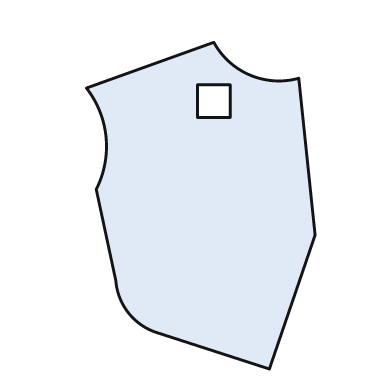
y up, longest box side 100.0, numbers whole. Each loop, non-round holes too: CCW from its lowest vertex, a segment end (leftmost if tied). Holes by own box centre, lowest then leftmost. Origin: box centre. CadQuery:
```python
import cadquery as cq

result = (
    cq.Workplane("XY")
    .moveTo(21.0, -50.0)
    .lineTo(35.0, -9.0)
    .lineTo(30.0, 39.0)
    .threePointArc((15.0, 40.0), (4.0, 50.0))
    .lineTo(-35.0, 36.0)
    .threePointArc((-29.0, 21.0), (-32.0, 5.0))
    .lineTo(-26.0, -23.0)
    .threePointArc((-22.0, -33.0), (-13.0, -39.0))
    .close()
    .moveTo(-1.0, 27.0)
    .lineTo(9.0, 27.0)
    .lineTo(9.0, 37.0)
    .lineTo(-1.0, 37.0)
    .close()
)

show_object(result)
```